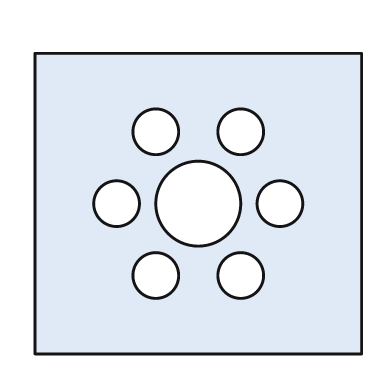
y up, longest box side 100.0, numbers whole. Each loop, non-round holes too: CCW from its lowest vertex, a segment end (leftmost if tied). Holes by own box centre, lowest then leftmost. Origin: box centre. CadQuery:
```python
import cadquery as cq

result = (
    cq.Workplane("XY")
    .moveTo(-50.0, -46.0)
    .lineTo(50.0, -46.0)
    .lineTo(50.0, 46.0)
    .lineTo(-50.0, 46.0)
    .close()
    .moveTo(-13.0, -22.0)
    .circle(7.0)
    .moveTo(13.0, -22.0)
    .circle(7.0)
    .moveTo(-25.0, 0.0)
    .circle(7.0)
    .moveTo(0.0, 0.0)
    .circle(13.0)
    .moveTo(25.0, 0.0)
    .circle(7.0)
    .moveTo(-13.0, 22.0)
    .circle(7.0)
    .moveTo(13.0, 22.0)
    .circle(7.0)
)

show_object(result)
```